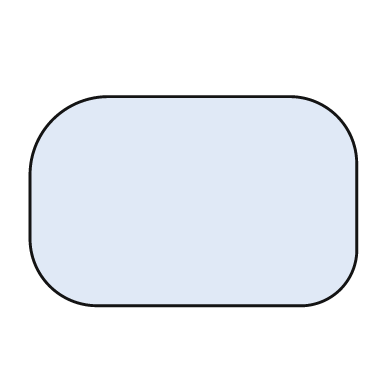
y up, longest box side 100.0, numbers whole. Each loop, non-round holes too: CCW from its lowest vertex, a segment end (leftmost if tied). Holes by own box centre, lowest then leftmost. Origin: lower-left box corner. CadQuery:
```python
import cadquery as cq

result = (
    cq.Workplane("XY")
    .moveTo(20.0, 0.0)
    .lineTo(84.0, 0.0)
    .threePointArc((95.0, 5.0), (100.0, 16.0))
    .lineTo(100.0, 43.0)
    .threePointArc((94.0, 58.0), (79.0, 64.0))
    .lineTo(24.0, 64.0)
    .threePointArc((7.0, 57.0), (0.0, 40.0))
    .lineTo(0.0, 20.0)
    .threePointArc((6.0, 6.0), (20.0, 0.0))
    .close()
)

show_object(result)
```